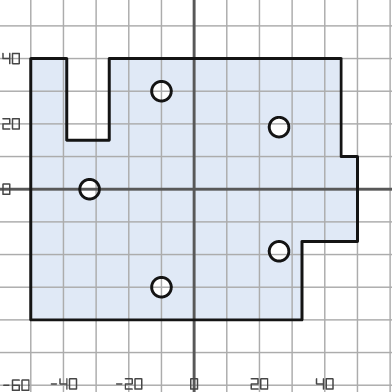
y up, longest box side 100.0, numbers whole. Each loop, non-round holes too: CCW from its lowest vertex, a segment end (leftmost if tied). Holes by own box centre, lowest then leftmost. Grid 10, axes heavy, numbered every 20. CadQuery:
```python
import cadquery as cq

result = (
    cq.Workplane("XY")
    .moveTo(-50.0, -40.0)
    .lineTo(33.0, -40.0)
    .lineTo(33.0, -16.0)
    .lineTo(50.0, -16.0)
    .lineTo(50.0, 10.0)
    .lineTo(45.0, 10.0)
    .lineTo(45.0, 40.0)
    .lineTo(-26.0, 40.0)
    .lineTo(-26.0, 15.0)
    .lineTo(-39.0, 15.0)
    .lineTo(-39.0, 40.0)
    .lineTo(-50.0, 40.0)
    .close()
    .moveTo(-10.0, -30.0)
    .circle(3.0)
    .moveTo(26.0, -19.0)
    .circle(3.0)
    .moveTo(-32.0, 0.0)
    .circle(3.0)
    .moveTo(26.0, 19.0)
    .circle(3.0)
    .moveTo(-10.0, 30.0)
    .circle(3.0)
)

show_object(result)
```